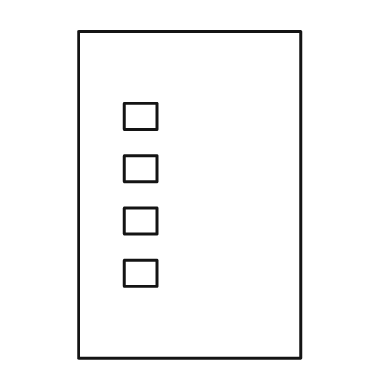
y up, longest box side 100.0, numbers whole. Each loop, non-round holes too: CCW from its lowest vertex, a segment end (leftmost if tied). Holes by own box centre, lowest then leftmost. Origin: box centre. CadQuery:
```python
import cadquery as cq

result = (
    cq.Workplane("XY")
    .moveTo(-34.0, -50.0)
    .lineTo(34.0, -50.0)
    .lineTo(34.0, 50.0)
    .lineTo(-34.0, 50.0)
    .close()
    .moveTo(-20.0, -28.0)
    .lineTo(-10.0, -28.0)
    .lineTo(-10.0, -20.0)
    .lineTo(-20.0, -20.0)
    .close()
    .moveTo(-20.0, -12.0)
    .lineTo(-10.0, -12.0)
    .lineTo(-10.0, -4.0)
    .lineTo(-20.0, -4.0)
    .close()
    .moveTo(-20.0, 4.0)
    .lineTo(-10.0, 4.0)
    .lineTo(-10.0, 12.0)
    .lineTo(-20.0, 12.0)
    .close()
    .moveTo(-20.0, 20.0)
    .lineTo(-10.0, 20.0)
    .lineTo(-10.0, 28.0)
    .lineTo(-20.0, 28.0)
    .close()
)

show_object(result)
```